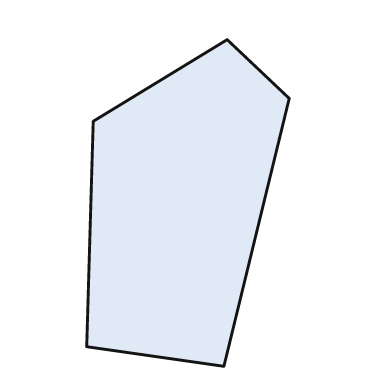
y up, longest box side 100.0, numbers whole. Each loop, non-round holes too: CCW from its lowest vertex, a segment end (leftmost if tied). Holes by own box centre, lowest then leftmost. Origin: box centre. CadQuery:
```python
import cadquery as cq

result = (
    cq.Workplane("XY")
    .moveTo(11.0, -50.0)
    .lineTo(31.0, 32.0)
    .lineTo(12.0, 50.0)
    .lineTo(-29.0, 25.0)
    .lineTo(-31.0, -44.0)
    .close()
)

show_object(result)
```